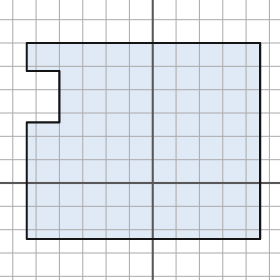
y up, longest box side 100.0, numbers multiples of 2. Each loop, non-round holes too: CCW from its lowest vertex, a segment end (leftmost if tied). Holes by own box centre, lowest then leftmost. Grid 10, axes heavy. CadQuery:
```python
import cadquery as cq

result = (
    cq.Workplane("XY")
    .moveTo(-54.0, -24.0)
    .lineTo(46.0, -24.0)
    .lineTo(46.0, 60.0)
    .lineTo(-54.0, 60.0)
    .lineTo(-54.0, 48.0)
    .lineTo(-40.0, 48.0)
    .lineTo(-40.0, 26.0)
    .lineTo(-54.0, 26.0)
    .close()
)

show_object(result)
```